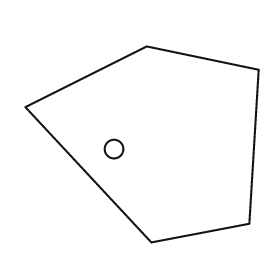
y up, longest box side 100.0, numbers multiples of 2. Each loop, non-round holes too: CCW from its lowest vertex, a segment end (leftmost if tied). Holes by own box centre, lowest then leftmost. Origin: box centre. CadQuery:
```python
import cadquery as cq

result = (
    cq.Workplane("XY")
    .moveTo(4.0, -42.0)
    .lineTo(46.0, -34.0)
    .lineTo(50.0, 32.0)
    .lineTo(2.0, 42.0)
    .lineTo(-50.0, 16.0)
    .close()
    .moveTo(-12.0, -2.0)
    .circle(4.0)
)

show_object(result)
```